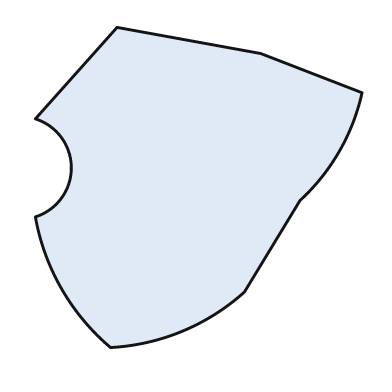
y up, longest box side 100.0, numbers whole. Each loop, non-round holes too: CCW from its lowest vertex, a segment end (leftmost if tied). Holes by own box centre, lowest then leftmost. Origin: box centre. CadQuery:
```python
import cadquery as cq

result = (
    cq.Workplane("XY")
    .moveTo(-27.0, -49.0)
    .threePointArc((-5.0, -44.0), (14.0, -32.0))
    .lineTo(31.0, -4.0)
    .threePointArc((43.0, 11.0), (50.0, 29.0))
    .lineTo(19.0, 41.0)
    .lineTo(-25.0, 49.0)
    .lineTo(-50.0, 21.0)
    .threePointArc((-39.0, 6.0), (-50.0, -9.0))
    .threePointArc((-42.0, -31.0), (-27.0, -49.0))
    .close()
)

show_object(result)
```